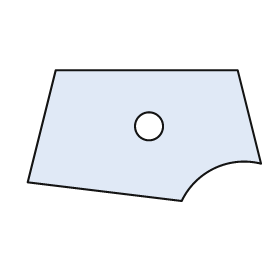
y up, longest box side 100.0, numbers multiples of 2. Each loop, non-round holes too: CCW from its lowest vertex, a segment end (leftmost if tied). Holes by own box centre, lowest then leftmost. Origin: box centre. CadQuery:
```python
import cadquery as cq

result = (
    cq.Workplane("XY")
    .moveTo(16.0, -28.0)
    .threePointArc((30.0, -14.0), (50.0, -12.0))
    .lineTo(40.0, 28.0)
    .lineTo(-38.0, 28.0)
    .lineTo(-50.0, -20.0)
    .close()
    .moveTo(2.0, 4.0)
    .circle(6.0)
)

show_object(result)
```